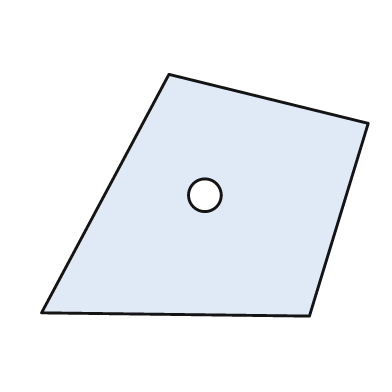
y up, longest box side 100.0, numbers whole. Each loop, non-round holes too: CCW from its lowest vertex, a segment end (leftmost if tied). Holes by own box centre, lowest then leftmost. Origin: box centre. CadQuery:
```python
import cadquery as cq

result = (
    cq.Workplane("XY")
    .moveTo(32.0, -37.0)
    .lineTo(50.0, 22.0)
    .lineTo(-11.0, 37.0)
    .lineTo(-50.0, -36.0)
    .close()
    .moveTo(0.0, 0.0)
    .circle(5.0)
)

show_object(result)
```